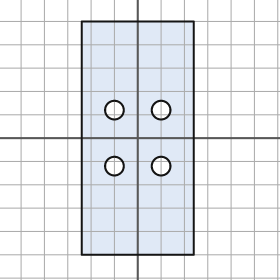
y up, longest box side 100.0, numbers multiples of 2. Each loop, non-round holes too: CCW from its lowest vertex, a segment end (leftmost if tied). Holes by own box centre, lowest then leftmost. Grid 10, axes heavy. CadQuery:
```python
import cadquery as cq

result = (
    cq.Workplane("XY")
    .moveTo(-24.0, -50.0)
    .lineTo(24.0, -50.0)
    .lineTo(24.0, 50.0)
    .lineTo(-24.0, 50.0)
    .close()
    .moveTo(-10.0, -12.0)
    .circle(4.0)
    .moveTo(10.0, -12.0)
    .circle(4.0)
    .moveTo(-10.0, 12.0)
    .circle(4.0)
    .moveTo(10.0, 12.0)
    .circle(4.0)
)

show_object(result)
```